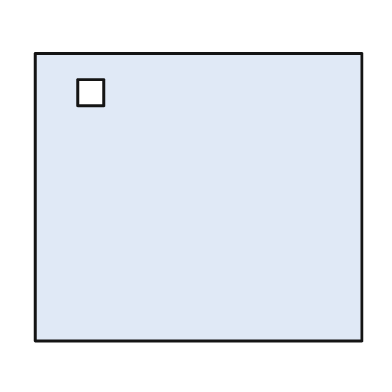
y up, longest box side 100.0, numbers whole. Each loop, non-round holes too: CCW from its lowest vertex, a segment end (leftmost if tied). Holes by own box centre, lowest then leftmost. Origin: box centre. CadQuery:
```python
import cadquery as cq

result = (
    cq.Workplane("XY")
    .moveTo(-50.0, -44.0)
    .lineTo(50.0, -44.0)
    .lineTo(50.0, 44.0)
    .lineTo(-50.0, 44.0)
    .close()
    .moveTo(-37.0, 28.0)
    .lineTo(-29.0, 28.0)
    .lineTo(-29.0, 36.0)
    .lineTo(-37.0, 36.0)
    .close()
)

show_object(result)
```